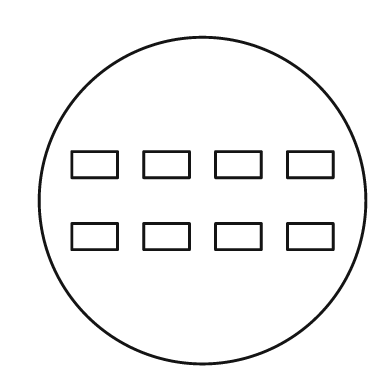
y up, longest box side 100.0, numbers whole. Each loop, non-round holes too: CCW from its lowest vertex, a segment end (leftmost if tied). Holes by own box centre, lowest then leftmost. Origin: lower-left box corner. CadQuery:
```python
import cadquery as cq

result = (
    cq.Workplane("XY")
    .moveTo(50.0, 50.0)
    .circle(50.0)
    .moveTo(10.0, 35.0)
    .lineTo(24.0, 35.0)
    .lineTo(24.0, 43.0)
    .lineTo(10.0, 43.0)
    .close()
    .moveTo(32.0, 35.0)
    .lineTo(46.0, 35.0)
    .lineTo(46.0, 43.0)
    .lineTo(32.0, 43.0)
    .close()
    .moveTo(54.0, 35.0)
    .lineTo(68.0, 35.0)
    .lineTo(68.0, 43.0)
    .lineTo(54.0, 43.0)
    .close()
    .moveTo(76.0, 35.0)
    .lineTo(90.0, 35.0)
    .lineTo(90.0, 43.0)
    .lineTo(76.0, 43.0)
    .close()
    .moveTo(10.0, 57.0)
    .lineTo(24.0, 57.0)
    .lineTo(24.0, 65.0)
    .lineTo(10.0, 65.0)
    .close()
    .moveTo(32.0, 57.0)
    .lineTo(46.0, 57.0)
    .lineTo(46.0, 65.0)
    .lineTo(32.0, 65.0)
    .close()
    .moveTo(54.0, 57.0)
    .lineTo(68.0, 57.0)
    .lineTo(68.0, 65.0)
    .lineTo(54.0, 65.0)
    .close()
    .moveTo(76.0, 57.0)
    .lineTo(90.0, 57.0)
    .lineTo(90.0, 65.0)
    .lineTo(76.0, 65.0)
    .close()
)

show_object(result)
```